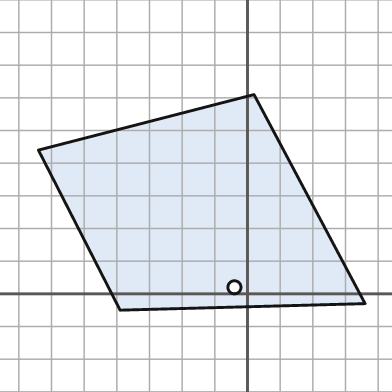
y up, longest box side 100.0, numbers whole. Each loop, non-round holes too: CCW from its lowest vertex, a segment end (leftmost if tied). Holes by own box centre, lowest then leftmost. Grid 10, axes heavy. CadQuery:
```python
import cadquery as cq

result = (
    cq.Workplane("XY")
    .moveTo(-39.0, -5.0)
    .lineTo(36.0, -3.0)
    .lineTo(2.0, 61.0)
    .lineTo(-64.0, 44.0)
    .close()
    .moveTo(-4.0, 2.0)
    .circle(2.0)
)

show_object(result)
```